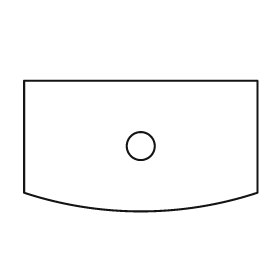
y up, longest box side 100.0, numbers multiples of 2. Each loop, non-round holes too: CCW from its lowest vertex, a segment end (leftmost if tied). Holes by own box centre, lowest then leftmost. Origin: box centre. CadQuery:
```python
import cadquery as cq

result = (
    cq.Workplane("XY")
    .moveTo(-50.0, -20.0)
    .threePointArc((0.0, -28.0), (50.0, -20.0))
    .lineTo(50.0, 28.0)
    .lineTo(-50.0, 28.0)
    .close()
    .moveTo(0.0, 0.0)
    .circle(6.0)
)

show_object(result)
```